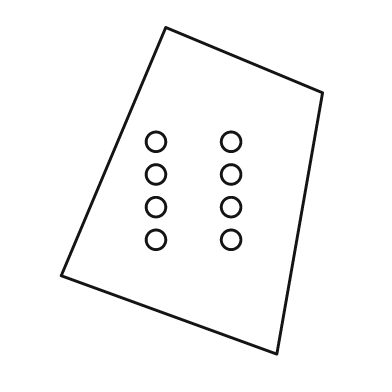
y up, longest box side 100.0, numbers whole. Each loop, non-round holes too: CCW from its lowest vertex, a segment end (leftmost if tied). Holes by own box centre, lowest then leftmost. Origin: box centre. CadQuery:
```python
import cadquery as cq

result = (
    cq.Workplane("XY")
    .moveTo(26.0, -50.0)
    .lineTo(40.0, 30.0)
    .lineTo(-8.0, 50.0)
    .lineTo(-40.0, -26.0)
    .close()
    .moveTo(-11.0, -15.0)
    .circle(3.0)
    .moveTo(12.0, -15.0)
    .circle(3.0)
    .moveTo(-11.0, -5.0)
    .circle(3.0)
    .moveTo(12.0, -5.0)
    .circle(3.0)
    .moveTo(-11.0, 5.0)
    .circle(3.0)
    .moveTo(12.0, 5.0)
    .circle(3.0)
    .moveTo(-11.0, 15.0)
    .circle(3.0)
    .moveTo(12.0, 15.0)
    .circle(3.0)
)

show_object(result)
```